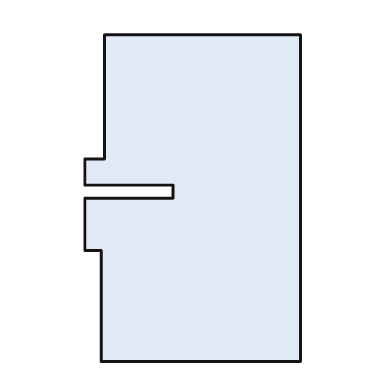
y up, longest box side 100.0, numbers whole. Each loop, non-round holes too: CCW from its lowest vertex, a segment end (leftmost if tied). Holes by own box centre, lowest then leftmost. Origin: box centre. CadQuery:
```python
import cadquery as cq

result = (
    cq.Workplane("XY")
    .moveTo(-28.0, -50.0)
    .lineTo(33.0, -50.0)
    .lineTo(33.0, 50.0)
    .lineTo(-27.0, 50.0)
    .lineTo(-27.0, 12.0)
    .lineTo(-33.0, 12.0)
    .lineTo(-33.0, 4.0)
    .lineTo(-6.0, 4.0)
    .lineTo(-6.0, 0.0)
    .lineTo(-33.0, 0.0)
    .lineTo(-33.0, -16.0)
    .lineTo(-28.0, -16.0)
    .close()
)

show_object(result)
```